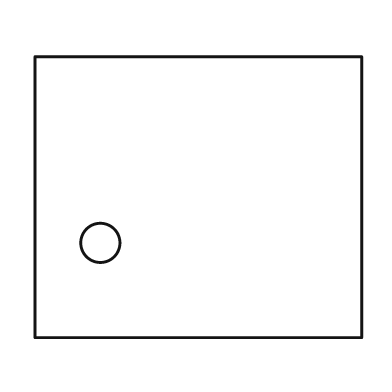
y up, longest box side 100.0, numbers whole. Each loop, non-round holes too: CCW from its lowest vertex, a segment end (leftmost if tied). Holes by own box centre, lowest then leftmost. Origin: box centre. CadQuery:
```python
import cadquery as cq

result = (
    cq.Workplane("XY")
    .moveTo(-50.0, -43.0)
    .lineTo(50.0, -43.0)
    .lineTo(50.0, 43.0)
    .lineTo(-50.0, 43.0)
    .close()
    .moveTo(-30.0, -14.0)
    .circle(6.0)
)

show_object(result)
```